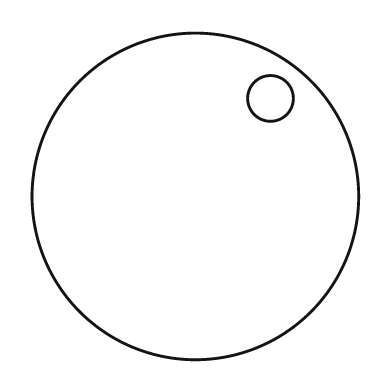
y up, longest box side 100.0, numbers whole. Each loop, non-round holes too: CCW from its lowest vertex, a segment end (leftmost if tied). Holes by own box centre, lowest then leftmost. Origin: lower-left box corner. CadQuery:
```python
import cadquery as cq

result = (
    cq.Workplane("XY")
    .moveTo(50.0, 50.0)
    .circle(50.0)
    .moveTo(73.0, 80.0)
    .circle(7.0)
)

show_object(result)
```